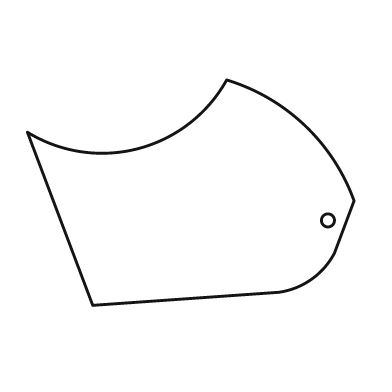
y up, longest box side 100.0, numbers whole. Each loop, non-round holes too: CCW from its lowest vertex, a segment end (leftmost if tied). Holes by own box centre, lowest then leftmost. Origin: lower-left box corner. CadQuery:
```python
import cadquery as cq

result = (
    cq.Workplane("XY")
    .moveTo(20.0, 0.0)
    .lineTo(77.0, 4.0)
    .threePointArc((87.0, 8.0), (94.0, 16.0))
    .lineTo(100.0, 32.0)
    .threePointArc((85.0, 55.0), (61.0, 69.0))
    .threePointArc((34.0, 48.0), (0.0, 53.0))
    .close()
    .moveTo(92.0, 26.0)
    .circle(2.0)
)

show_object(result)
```